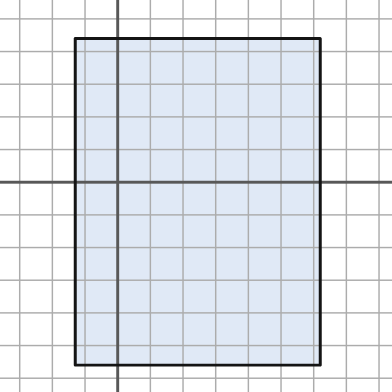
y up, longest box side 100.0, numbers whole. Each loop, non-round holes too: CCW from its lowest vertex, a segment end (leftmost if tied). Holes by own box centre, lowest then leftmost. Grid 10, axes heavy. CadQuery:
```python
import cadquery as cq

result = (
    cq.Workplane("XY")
    .moveTo(-13.0, -56.0)
    .lineTo(62.0, -56.0)
    .lineTo(62.0, 44.0)
    .lineTo(-13.0, 44.0)
    .close()
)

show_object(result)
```